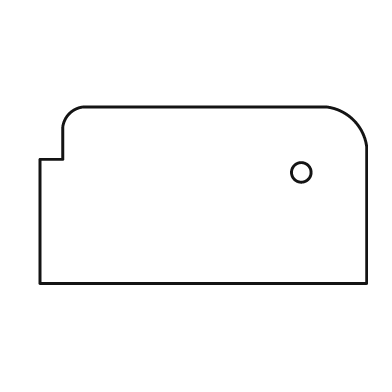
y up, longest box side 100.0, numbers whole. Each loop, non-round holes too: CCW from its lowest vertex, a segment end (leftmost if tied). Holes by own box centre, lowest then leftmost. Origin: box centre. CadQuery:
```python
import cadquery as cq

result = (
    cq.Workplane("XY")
    .moveTo(-50.0, -27.0)
    .lineTo(50.0, -27.0)
    .lineTo(50.0, 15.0)
    .threePointArc((46.0, 23.0), (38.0, 27.0))
    .lineTo(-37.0, 27.0)
    .threePointArc((-41.0, 25.0), (-43.0, 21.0))
    .lineTo(-43.0, 11.0)
    .lineTo(-50.0, 11.0)
    .close()
    .moveTo(30.0, 7.0)
    .circle(3.0)
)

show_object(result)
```